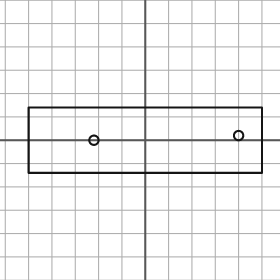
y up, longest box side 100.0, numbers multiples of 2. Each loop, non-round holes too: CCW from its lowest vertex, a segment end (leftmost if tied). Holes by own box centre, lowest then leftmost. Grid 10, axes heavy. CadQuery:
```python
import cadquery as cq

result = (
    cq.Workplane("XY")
    .moveTo(-50.0, -14.0)
    .lineTo(50.0, -14.0)
    .lineTo(50.0, 14.0)
    .lineTo(-50.0, 14.0)
    .close()
    .moveTo(-22.0, 0.0)
    .circle(2.0)
    .moveTo(40.0, 2.0)
    .circle(2.0)
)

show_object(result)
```